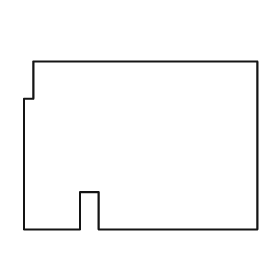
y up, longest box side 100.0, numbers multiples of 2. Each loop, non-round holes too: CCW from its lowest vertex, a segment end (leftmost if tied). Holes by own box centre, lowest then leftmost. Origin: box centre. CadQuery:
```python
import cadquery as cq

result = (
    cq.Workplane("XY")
    .moveTo(-50.0, -36.0)
    .lineTo(-26.0, -36.0)
    .lineTo(-26.0, -20.0)
    .lineTo(-18.0, -20.0)
    .lineTo(-18.0, -36.0)
    .lineTo(50.0, -36.0)
    .lineTo(50.0, 36.0)
    .lineTo(-46.0, 36.0)
    .lineTo(-46.0, 20.0)
    .lineTo(-50.0, 20.0)
    .close()
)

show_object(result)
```